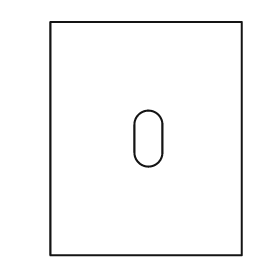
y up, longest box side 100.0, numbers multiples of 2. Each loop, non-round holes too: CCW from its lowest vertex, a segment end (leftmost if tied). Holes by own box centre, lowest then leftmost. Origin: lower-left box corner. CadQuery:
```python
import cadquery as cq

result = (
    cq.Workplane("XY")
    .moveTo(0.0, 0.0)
    .lineTo(82.0, 0.0)
    .lineTo(82.0, 100.0)
    .lineTo(0.0, 100.0)
    .close()
    .moveTo(36.0, 44.0)
    .threePointArc((42.0, 38.0), (48.0, 44.0))
    .lineTo(48.0, 56.0)
    .threePointArc((42.0, 62.0), (36.0, 56.0))
    .close()
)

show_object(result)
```